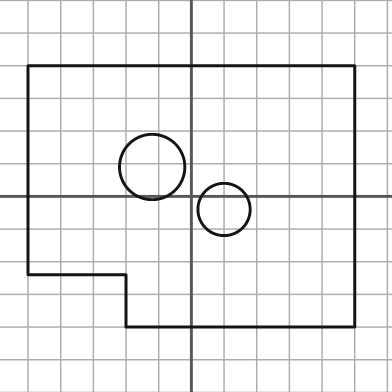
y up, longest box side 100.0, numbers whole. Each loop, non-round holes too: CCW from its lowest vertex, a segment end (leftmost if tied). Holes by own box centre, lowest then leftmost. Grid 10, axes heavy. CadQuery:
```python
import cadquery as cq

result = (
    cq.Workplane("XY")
    .moveTo(-20.0, -40.0)
    .lineTo(50.0, -40.0)
    .lineTo(50.0, 40.0)
    .lineTo(-50.0, 40.0)
    .lineTo(-50.0, -24.0)
    .lineTo(-20.0, -24.0)
    .close()
    .moveTo(10.0, -4.0)
    .circle(8.0)
    .moveTo(-12.0, 9.0)
    .circle(10.0)
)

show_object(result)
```